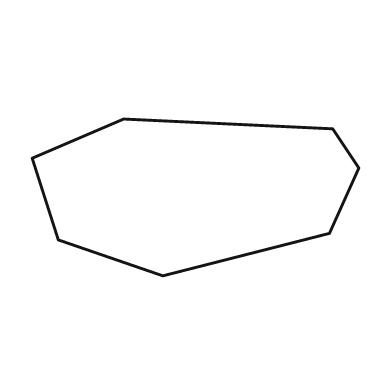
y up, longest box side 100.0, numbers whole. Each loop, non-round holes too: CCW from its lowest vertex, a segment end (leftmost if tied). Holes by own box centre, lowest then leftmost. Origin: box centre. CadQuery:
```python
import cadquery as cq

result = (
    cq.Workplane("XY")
    .moveTo(-10.0, -24.0)
    .lineTo(41.0, -11.0)
    .lineTo(50.0, 9.0)
    .lineTo(42.0, 21.0)
    .lineTo(-22.0, 24.0)
    .lineTo(-50.0, 12.0)
    .lineTo(-42.0, -13.0)
    .close()
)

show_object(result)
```